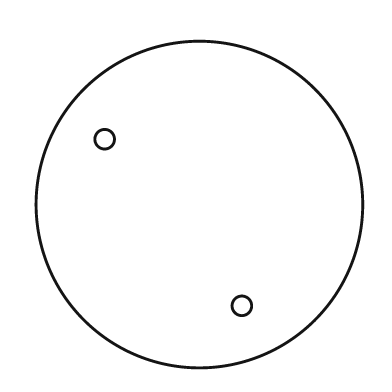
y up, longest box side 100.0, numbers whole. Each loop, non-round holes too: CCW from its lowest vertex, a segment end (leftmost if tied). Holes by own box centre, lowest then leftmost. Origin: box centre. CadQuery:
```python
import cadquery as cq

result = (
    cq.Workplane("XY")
    .moveTo(0.0, 0.0)
    .circle(50.0)
    .moveTo(13.0, -31.0)
    .circle(3.0)
    .moveTo(-29.0, 20.0)
    .circle(3.0)
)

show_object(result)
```